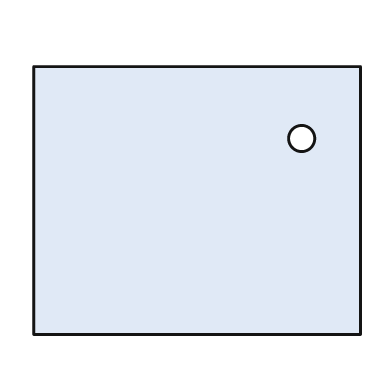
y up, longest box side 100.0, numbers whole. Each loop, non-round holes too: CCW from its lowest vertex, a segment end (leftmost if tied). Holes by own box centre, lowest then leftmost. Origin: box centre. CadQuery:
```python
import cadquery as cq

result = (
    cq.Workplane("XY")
    .moveTo(-50.0, -41.0)
    .lineTo(50.0, -41.0)
    .lineTo(50.0, 41.0)
    .lineTo(-50.0, 41.0)
    .close()
    .moveTo(32.0, 19.0)
    .circle(4.0)
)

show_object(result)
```